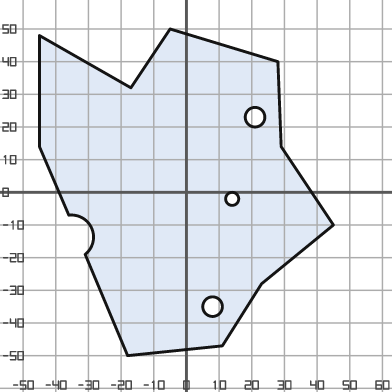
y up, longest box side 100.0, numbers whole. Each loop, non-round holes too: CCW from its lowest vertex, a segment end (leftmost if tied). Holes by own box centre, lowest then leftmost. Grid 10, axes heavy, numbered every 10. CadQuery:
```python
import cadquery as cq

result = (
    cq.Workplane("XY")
    .moveTo(-18.0, -50.0)
    .lineTo(11.0, -47.0)
    .lineTo(23.0, -28.0)
    .lineTo(45.0, -10.0)
    .lineTo(29.0, 14.0)
    .lineTo(28.0, 40.0)
    .lineTo(-5.0, 50.0)
    .lineTo(-17.0, 32.0)
    .lineTo(-45.0, 48.0)
    .lineTo(-45.0, 14.0)
    .lineTo(-36.0, -7.0)
    .threePointArc((-29.0, -11.0), (-31.0, -19.0))
    .close()
    .moveTo(8.0, -35.0)
    .circle(3.0)
    .moveTo(14.0, -2.0)
    .circle(2.0)
    .moveTo(21.0, 23.0)
    .circle(3.0)
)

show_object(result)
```